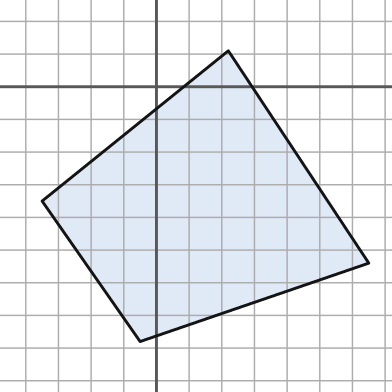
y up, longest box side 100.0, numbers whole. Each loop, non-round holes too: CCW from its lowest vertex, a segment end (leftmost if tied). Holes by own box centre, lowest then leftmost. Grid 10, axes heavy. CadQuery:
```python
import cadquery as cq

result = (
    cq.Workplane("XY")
    .moveTo(-5.0, -78.0)
    .lineTo(65.0, -54.0)
    .lineTo(22.0, 11.0)
    .lineTo(-35.0, -35.0)
    .close()
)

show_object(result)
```